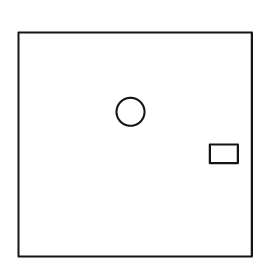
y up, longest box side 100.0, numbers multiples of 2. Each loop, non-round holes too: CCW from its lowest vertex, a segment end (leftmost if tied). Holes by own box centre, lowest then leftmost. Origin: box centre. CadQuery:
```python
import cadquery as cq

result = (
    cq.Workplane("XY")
    .moveTo(-50.0, -48.0)
    .lineTo(50.0, -48.0)
    .lineTo(50.0, 48.0)
    .lineTo(-50.0, 48.0)
    .close()
    .moveTo(32.0, -8.0)
    .lineTo(44.0, -8.0)
    .lineTo(44.0, 0.0)
    .lineTo(32.0, 0.0)
    .close()
    .moveTo(-2.0, 14.0)
    .circle(6.0)
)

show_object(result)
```